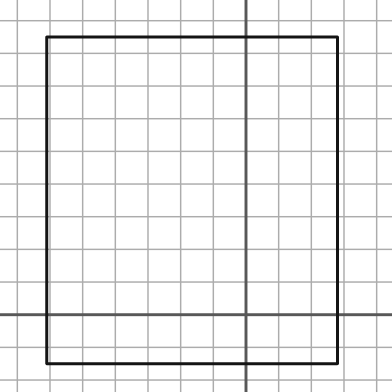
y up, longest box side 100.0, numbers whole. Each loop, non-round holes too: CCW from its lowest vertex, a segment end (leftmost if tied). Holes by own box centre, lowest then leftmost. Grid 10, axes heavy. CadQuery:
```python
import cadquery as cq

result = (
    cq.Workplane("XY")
    .moveTo(-61.0, -15.0)
    .lineTo(28.0, -15.0)
    .lineTo(28.0, 85.0)
    .lineTo(-61.0, 85.0)
    .close()
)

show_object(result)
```